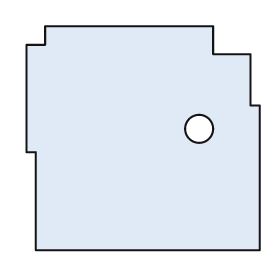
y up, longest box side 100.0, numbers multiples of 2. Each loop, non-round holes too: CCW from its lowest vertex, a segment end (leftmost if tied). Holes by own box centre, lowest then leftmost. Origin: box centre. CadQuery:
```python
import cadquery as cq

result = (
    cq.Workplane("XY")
    .moveTo(-46.0, -48.0)
    .lineTo(50.0, -48.0)
    .lineTo(50.0, 14.0)
    .lineTo(46.0, 14.0)
    .lineTo(46.0, 36.0)
    .lineTo(30.0, 36.0)
    .lineTo(30.0, 48.0)
    .lineTo(-42.0, 48.0)
    .lineTo(-42.0, 40.0)
    .lineTo(-50.0, 40.0)
    .lineTo(-50.0, -6.0)
    .lineTo(-46.0, -6.0)
    .close()
    .moveTo(24.0, 4.0)
    .circle(6.0)
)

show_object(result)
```